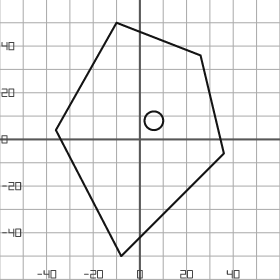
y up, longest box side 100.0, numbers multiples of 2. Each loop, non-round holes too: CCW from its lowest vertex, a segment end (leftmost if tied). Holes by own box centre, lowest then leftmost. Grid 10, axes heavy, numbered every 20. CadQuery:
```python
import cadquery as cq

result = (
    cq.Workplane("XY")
    .moveTo(-8.0, -50.0)
    .lineTo(36.0, -6.0)
    .lineTo(26.0, 36.0)
    .lineTo(-10.0, 50.0)
    .lineTo(-36.0, 4.0)
    .close()
    .moveTo(6.0, 8.0)
    .circle(4.0)
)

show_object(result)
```